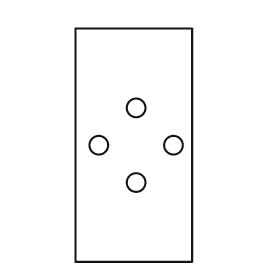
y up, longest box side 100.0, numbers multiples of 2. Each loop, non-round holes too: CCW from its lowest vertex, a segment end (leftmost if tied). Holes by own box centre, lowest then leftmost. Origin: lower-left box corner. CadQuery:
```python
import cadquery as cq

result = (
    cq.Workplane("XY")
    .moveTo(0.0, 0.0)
    .lineTo(50.0, 0.0)
    .lineTo(50.0, 100.0)
    .lineTo(0.0, 100.0)
    .close()
    .moveTo(26.0, 34.0)
    .circle(4.0)
    .moveTo(10.0, 50.0)
    .circle(4.0)
    .moveTo(42.0, 50.0)
    .circle(4.0)
    .moveTo(26.0, 66.0)
    .circle(4.0)
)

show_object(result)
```